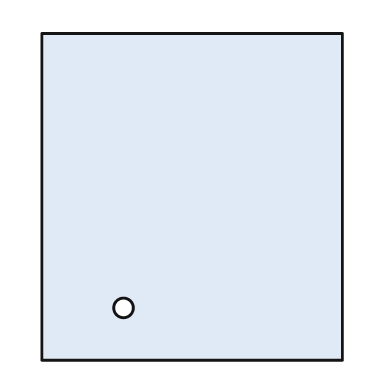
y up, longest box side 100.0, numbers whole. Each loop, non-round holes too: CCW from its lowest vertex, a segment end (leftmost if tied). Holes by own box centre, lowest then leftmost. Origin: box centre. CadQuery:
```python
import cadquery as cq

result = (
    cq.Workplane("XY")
    .moveTo(-46.0, -50.0)
    .lineTo(46.0, -50.0)
    .lineTo(46.0, 50.0)
    .lineTo(-46.0, 50.0)
    .close()
    .moveTo(-21.0, -34.0)
    .circle(3.0)
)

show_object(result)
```